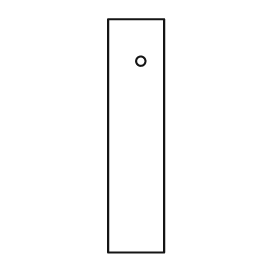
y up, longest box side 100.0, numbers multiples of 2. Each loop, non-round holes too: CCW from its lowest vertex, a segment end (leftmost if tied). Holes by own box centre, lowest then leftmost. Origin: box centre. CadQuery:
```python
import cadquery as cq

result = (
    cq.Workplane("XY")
    .moveTo(-12.0, -50.0)
    .lineTo(12.0, -50.0)
    .lineTo(12.0, 50.0)
    .lineTo(-12.0, 50.0)
    .close()
    .moveTo(2.0, 32.0)
    .circle(2.0)
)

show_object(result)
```